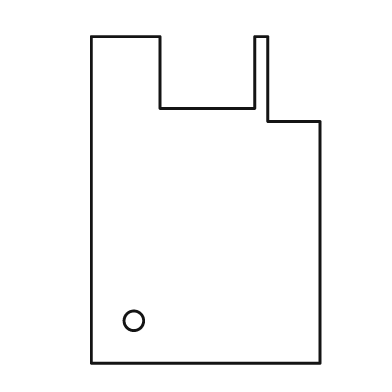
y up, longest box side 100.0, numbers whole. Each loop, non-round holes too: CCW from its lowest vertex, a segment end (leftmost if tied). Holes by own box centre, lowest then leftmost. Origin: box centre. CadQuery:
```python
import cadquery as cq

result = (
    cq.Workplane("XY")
    .moveTo(-35.0, -50.0)
    .lineTo(35.0, -50.0)
    .lineTo(35.0, 24.0)
    .lineTo(19.0, 24.0)
    .lineTo(19.0, 50.0)
    .lineTo(15.0, 50.0)
    .lineTo(15.0, 28.0)
    .lineTo(-14.0, 28.0)
    .lineTo(-14.0, 50.0)
    .lineTo(-35.0, 50.0)
    .close()
    .moveTo(-22.0, -37.0)
    .circle(3.0)
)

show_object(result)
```